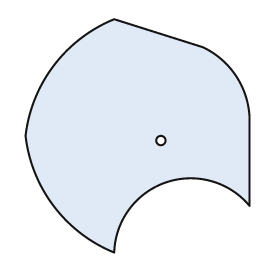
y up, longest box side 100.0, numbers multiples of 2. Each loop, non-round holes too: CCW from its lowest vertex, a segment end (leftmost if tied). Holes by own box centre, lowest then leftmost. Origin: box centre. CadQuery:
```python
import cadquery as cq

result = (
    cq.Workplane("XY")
    .moveTo(-10.0, -50.0)
    .threePointArc((12.0, -20.0), (48.0, -30.0))
    .lineTo(48.0, 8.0)
    .threePointArc((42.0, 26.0), (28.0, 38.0))
    .lineTo(-10.0, 50.0)
    .threePointArc((-36.0, 30.0), (-48.0, 0.0))
    .threePointArc((-36.0, -30.0), (-10.0, -50.0))
    .close()
    .moveTo(10.0, -2.0)
    .circle(2.0)
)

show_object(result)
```